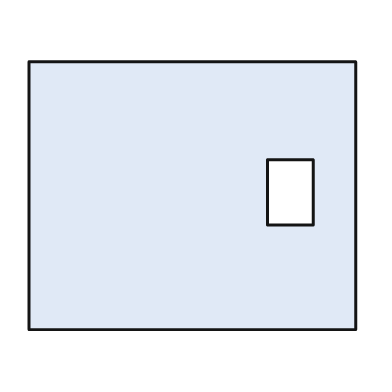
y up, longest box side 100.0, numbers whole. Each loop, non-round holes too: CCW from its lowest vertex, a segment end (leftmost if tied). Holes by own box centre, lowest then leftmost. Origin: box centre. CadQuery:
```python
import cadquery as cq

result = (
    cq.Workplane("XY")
    .moveTo(-50.0, -41.0)
    .lineTo(50.0, -41.0)
    .lineTo(50.0, 41.0)
    .lineTo(-50.0, 41.0)
    .close()
    .moveTo(23.0, -9.0)
    .lineTo(37.0, -9.0)
    .lineTo(37.0, 11.0)
    .lineTo(23.0, 11.0)
    .close()
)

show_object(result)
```